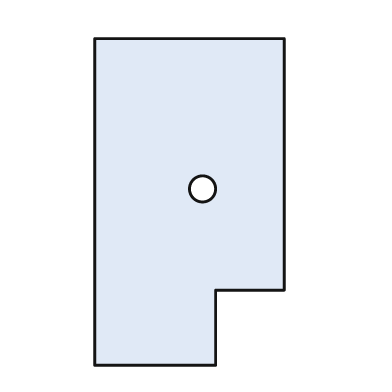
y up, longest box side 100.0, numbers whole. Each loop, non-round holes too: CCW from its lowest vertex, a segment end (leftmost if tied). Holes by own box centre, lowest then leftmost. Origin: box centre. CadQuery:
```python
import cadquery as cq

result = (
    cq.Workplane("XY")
    .moveTo(-29.0, -50.0)
    .lineTo(8.0, -50.0)
    .lineTo(8.0, -27.0)
    .lineTo(29.0, -27.0)
    .lineTo(29.0, 50.0)
    .lineTo(-29.0, 50.0)
    .close()
    .moveTo(4.0, 4.0)
    .circle(4.0)
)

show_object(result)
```